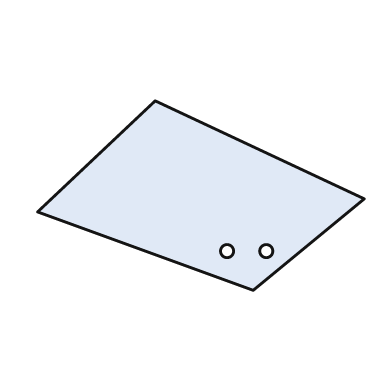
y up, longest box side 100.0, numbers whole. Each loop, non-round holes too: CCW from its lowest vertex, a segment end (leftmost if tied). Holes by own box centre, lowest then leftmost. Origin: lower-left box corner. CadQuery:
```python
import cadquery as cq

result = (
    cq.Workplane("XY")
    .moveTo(66.0, 0.0)
    .lineTo(100.0, 28.0)
    .lineTo(36.0, 58.0)
    .lineTo(0.0, 24.0)
    .close()
    .moveTo(58.0, 12.0)
    .circle(2.0)
    .moveTo(70.0, 12.0)
    .circle(2.0)
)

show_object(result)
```